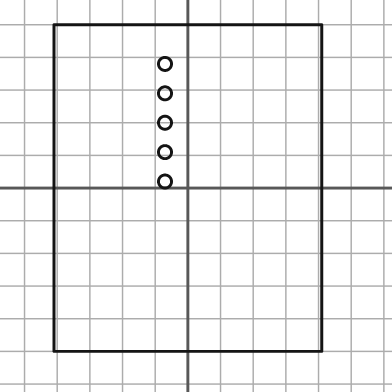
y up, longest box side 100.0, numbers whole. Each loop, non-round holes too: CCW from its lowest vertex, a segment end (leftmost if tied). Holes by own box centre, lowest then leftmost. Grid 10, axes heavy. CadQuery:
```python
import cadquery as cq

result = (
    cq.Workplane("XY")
    .moveTo(-41.0, -50.0)
    .lineTo(41.0, -50.0)
    .lineTo(41.0, 50.0)
    .lineTo(-41.0, 50.0)
    .close()
    .moveTo(-7.0, 2.0)
    .circle(2.0)
    .moveTo(-7.0, 11.0)
    .circle(2.0)
    .moveTo(-7.0, 20.0)
    .circle(2.0)
    .moveTo(-7.0, 29.0)
    .circle(2.0)
    .moveTo(-7.0, 38.0)
    .circle(2.0)
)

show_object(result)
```